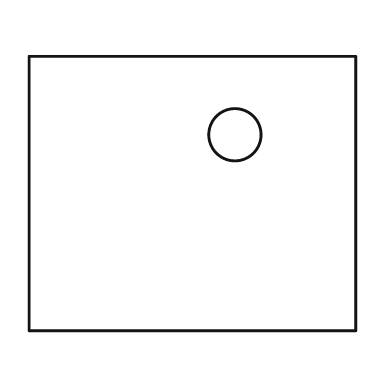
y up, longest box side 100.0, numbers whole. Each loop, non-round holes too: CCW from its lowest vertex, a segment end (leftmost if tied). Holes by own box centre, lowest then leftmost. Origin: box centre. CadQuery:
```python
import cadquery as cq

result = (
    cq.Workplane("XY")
    .moveTo(-50.0, -42.0)
    .lineTo(50.0, -42.0)
    .lineTo(50.0, 42.0)
    .lineTo(-50.0, 42.0)
    .close()
    .moveTo(13.0, 18.0)
    .circle(8.0)
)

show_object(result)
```